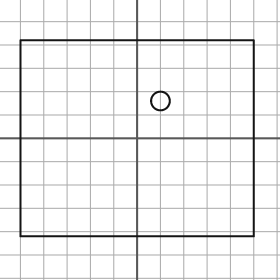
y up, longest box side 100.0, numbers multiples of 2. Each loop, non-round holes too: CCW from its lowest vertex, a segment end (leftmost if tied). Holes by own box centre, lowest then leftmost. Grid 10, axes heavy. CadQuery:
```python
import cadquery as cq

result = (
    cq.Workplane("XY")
    .moveTo(-50.0, -42.0)
    .lineTo(50.0, -42.0)
    .lineTo(50.0, 42.0)
    .lineTo(-50.0, 42.0)
    .close()
    .moveTo(10.0, 16.0)
    .circle(4.0)
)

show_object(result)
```